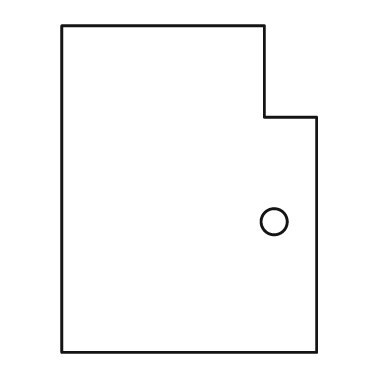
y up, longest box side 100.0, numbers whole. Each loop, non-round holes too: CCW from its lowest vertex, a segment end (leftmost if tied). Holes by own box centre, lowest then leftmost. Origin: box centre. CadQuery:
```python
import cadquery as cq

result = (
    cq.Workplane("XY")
    .moveTo(-39.0, -50.0)
    .lineTo(39.0, -50.0)
    .lineTo(39.0, 22.0)
    .lineTo(23.0, 22.0)
    .lineTo(23.0, 50.0)
    .lineTo(-39.0, 50.0)
    .close()
    .moveTo(26.0, -10.0)
    .circle(4.0)
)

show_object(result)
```